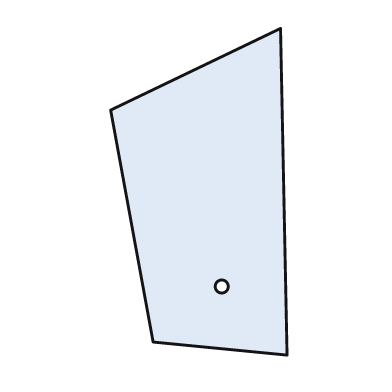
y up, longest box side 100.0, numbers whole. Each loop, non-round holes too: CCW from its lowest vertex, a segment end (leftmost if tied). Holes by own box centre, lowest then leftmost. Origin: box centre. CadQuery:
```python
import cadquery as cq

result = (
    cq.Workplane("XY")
    .moveTo(27.0, -50.0)
    .lineTo(25.0, 50.0)
    .lineTo(-27.0, 25.0)
    .lineTo(-14.0, -46.0)
    .close()
    .moveTo(7.0, -29.0)
    .circle(2.0)
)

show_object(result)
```